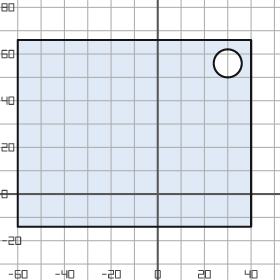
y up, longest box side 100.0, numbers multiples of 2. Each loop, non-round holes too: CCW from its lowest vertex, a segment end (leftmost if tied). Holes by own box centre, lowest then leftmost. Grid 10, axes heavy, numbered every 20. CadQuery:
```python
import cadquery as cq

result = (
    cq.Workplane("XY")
    .moveTo(-60.0, -14.0)
    .lineTo(40.0, -14.0)
    .lineTo(40.0, 66.0)
    .lineTo(-60.0, 66.0)
    .close()
    .moveTo(30.0, 56.0)
    .circle(6.0)
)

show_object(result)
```